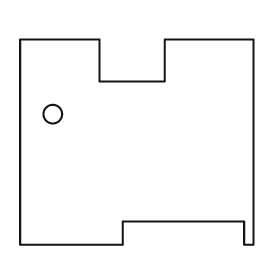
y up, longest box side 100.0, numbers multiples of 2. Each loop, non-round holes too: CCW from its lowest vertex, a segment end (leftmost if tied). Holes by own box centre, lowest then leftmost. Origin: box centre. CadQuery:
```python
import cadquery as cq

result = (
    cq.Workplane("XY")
    .moveTo(-50.0, -44.0)
    .lineTo(-6.0, -44.0)
    .lineTo(-6.0, -34.0)
    .lineTo(46.0, -34.0)
    .lineTo(46.0, -44.0)
    .lineTo(50.0, -44.0)
    .lineTo(50.0, 44.0)
    .lineTo(12.0, 44.0)
    .lineTo(12.0, 26.0)
    .lineTo(-16.0, 26.0)
    .lineTo(-16.0, 44.0)
    .lineTo(-50.0, 44.0)
    .close()
    .moveTo(-36.0, 12.0)
    .circle(4.0)
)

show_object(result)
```